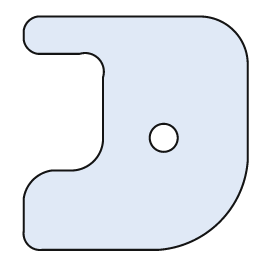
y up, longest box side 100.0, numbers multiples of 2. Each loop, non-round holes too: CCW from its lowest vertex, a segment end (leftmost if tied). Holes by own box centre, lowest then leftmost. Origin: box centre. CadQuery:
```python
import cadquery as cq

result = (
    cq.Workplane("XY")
    .moveTo(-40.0, -50.0)
    .lineTo(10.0, -50.0)
    .threePointArc((36.0, -38.0), (48.0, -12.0))
    .lineTo(48.0, 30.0)
    .threePointArc((42.0, 44.0), (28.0, 50.0))
    .lineTo(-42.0, 50.0)
    .threePointArc((-46.0, 48.0), (-48.0, 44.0))
    .lineTo(-48.0, 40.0)
    .threePointArc((-46.0, 36.0), (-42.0, 34.0))
    .lineTo(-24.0, 34.0)
    .threePointArc((-16.0, 32.0), (-14.0, 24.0))
    .lineTo(-14.0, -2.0)
    .threePointArc((-18.0, -12.0), (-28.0, -16.0))
    .lineTo(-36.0, -16.0)
    .threePointArc((-44.0, -20.0), (-48.0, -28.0))
    .lineTo(-48.0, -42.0)
    .threePointArc((-46.0, -48.0), (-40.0, -50.0))
    .close()
    .moveTo(12.0, -2.0)
    .circle(6.0)
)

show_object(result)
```